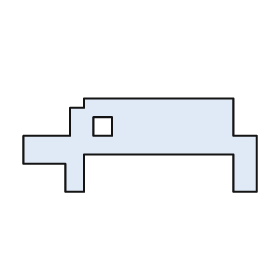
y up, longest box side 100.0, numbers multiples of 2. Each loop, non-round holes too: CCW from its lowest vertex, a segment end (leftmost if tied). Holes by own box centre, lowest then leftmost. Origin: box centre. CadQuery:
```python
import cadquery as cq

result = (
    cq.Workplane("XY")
    .moveTo(-32.0, -20.0)
    .lineTo(-24.0, -20.0)
    .lineTo(-24.0, -4.0)
    .lineTo(40.0, -4.0)
    .lineTo(40.0, -20.0)
    .lineTo(50.0, -20.0)
    .lineTo(50.0, 4.0)
    .lineTo(40.0, 4.0)
    .lineTo(40.0, 20.0)
    .lineTo(-24.0, 20.0)
    .lineTo(-24.0, 16.0)
    .lineTo(-30.0, 16.0)
    .lineTo(-30.0, 4.0)
    .lineTo(-50.0, 4.0)
    .lineTo(-50.0, -8.0)
    .lineTo(-32.0, -8.0)
    .close()
    .moveTo(-20.0, 4.0)
    .lineTo(-12.0, 4.0)
    .lineTo(-12.0, 12.0)
    .lineTo(-20.0, 12.0)
    .close()
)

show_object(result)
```